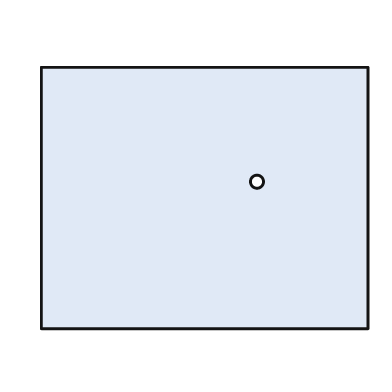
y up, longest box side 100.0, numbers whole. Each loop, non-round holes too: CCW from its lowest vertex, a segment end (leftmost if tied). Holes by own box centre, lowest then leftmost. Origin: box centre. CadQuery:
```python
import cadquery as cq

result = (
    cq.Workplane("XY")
    .moveTo(-50.0, -40.0)
    .lineTo(50.0, -40.0)
    .lineTo(50.0, 40.0)
    .lineTo(-50.0, 40.0)
    .close()
    .moveTo(16.0, 5.0)
    .circle(2.0)
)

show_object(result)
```